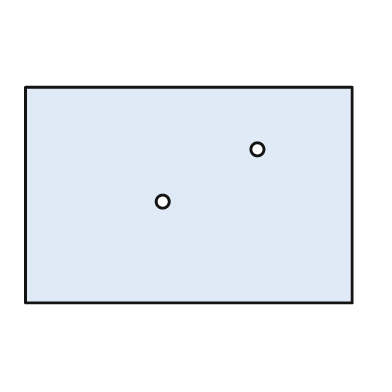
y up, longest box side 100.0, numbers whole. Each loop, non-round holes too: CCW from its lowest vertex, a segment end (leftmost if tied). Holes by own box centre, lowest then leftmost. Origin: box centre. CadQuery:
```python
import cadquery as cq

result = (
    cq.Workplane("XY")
    .moveTo(-50.0, -33.0)
    .lineTo(50.0, -33.0)
    .lineTo(50.0, 33.0)
    .lineTo(-50.0, 33.0)
    .close()
    .moveTo(-8.0, -2.0)
    .circle(2.0)
    .moveTo(21.0, 14.0)
    .circle(2.0)
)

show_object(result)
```